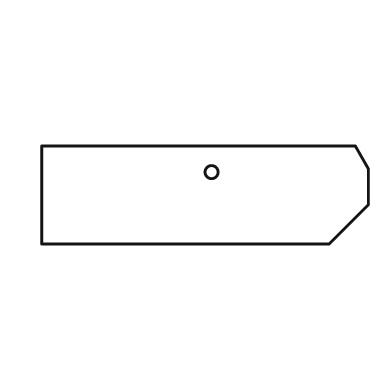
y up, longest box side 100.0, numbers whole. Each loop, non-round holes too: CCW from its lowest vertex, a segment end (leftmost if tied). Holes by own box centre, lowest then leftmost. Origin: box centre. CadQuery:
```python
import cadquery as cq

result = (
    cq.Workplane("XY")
    .moveTo(-50.0, -15.0)
    .lineTo(38.0, -15.0)
    .lineTo(50.0, -3.0)
    .lineTo(50.0, 8.0)
    .lineTo(46.0, 15.0)
    .lineTo(-50.0, 15.0)
    .close()
    .moveTo(2.0, 7.0)
    .circle(2.0)
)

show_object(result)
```